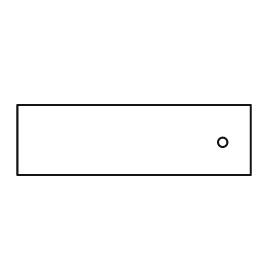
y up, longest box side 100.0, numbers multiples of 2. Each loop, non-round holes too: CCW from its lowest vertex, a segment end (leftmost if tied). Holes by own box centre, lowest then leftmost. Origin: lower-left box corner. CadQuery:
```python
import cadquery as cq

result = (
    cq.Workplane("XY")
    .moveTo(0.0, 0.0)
    .lineTo(100.0, 0.0)
    .lineTo(100.0, 30.0)
    .lineTo(0.0, 30.0)
    .close()
    .moveTo(88.0, 14.0)
    .circle(2.0)
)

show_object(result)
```